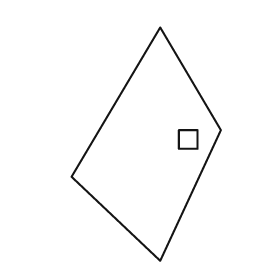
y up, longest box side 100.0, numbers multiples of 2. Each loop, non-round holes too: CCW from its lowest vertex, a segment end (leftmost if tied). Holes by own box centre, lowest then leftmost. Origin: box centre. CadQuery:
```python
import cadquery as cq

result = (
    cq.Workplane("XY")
    .moveTo(6.0, -50.0)
    .lineTo(32.0, 6.0)
    .lineTo(6.0, 50.0)
    .lineTo(-32.0, -14.0)
    .close()
    .moveTo(14.0, -2.0)
    .lineTo(22.0, -2.0)
    .lineTo(22.0, 6.0)
    .lineTo(14.0, 6.0)
    .close()
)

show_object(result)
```